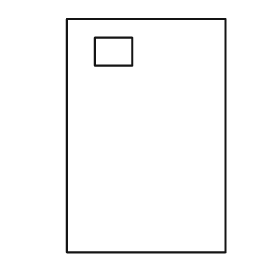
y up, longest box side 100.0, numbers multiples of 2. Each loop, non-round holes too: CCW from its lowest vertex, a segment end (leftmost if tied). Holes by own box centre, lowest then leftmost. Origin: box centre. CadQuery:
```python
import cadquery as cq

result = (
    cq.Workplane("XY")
    .moveTo(-34.0, -50.0)
    .lineTo(34.0, -50.0)
    .lineTo(34.0, 50.0)
    .lineTo(-34.0, 50.0)
    .close()
    .moveTo(-22.0, 30.0)
    .lineTo(-6.0, 30.0)
    .lineTo(-6.0, 42.0)
    .lineTo(-22.0, 42.0)
    .close()
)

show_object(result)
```